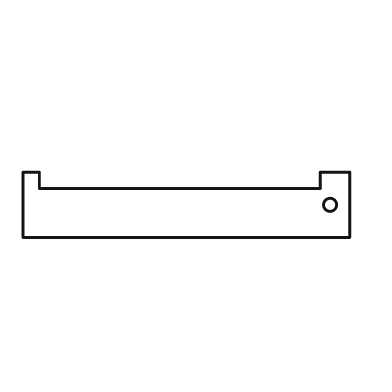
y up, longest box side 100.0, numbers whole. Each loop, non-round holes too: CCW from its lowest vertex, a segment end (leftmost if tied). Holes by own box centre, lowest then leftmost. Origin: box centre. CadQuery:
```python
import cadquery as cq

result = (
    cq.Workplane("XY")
    .moveTo(-50.0, -10.0)
    .lineTo(50.0, -10.0)
    .lineTo(50.0, 10.0)
    .lineTo(41.0, 10.0)
    .lineTo(41.0, 5.0)
    .lineTo(-45.0, 5.0)
    .lineTo(-45.0, 10.0)
    .lineTo(-50.0, 10.0)
    .close()
    .moveTo(44.0, 0.0)
    .circle(2.0)
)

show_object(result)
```